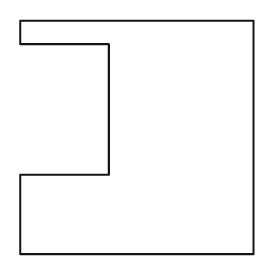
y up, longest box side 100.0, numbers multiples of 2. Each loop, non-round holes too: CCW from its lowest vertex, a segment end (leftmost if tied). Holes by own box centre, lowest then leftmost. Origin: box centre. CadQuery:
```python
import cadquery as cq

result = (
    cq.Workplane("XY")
    .moveTo(-50.0, -50.0)
    .lineTo(50.0, -50.0)
    .lineTo(50.0, 50.0)
    .lineTo(-50.0, 50.0)
    .lineTo(-50.0, 40.0)
    .lineTo(-12.0, 40.0)
    .lineTo(-12.0, -16.0)
    .lineTo(-50.0, -16.0)
    .close()
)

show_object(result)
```